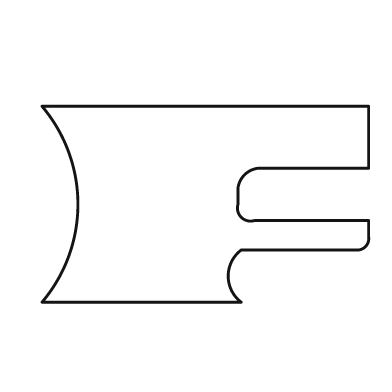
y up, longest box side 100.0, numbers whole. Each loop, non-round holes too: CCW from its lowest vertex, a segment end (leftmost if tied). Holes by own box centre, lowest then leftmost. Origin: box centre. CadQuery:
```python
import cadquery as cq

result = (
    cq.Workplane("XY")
    .moveTo(-50.0, -30.0)
    .lineTo(11.0, -30.0)
    .threePointArc((7.0, -22.0), (11.0, -14.0))
    .lineTo(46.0, -14.0)
    .threePointArc((49.0, -13.0), (50.0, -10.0))
    .lineTo(50.0, -5.0)
    .lineTo(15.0, -5.0)
    .threePointArc((11.0, -4.0), (10.0, 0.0))
    .lineTo(10.0, 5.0)
    .threePointArc((12.0, 9.0), (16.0, 11.0))
    .lineTo(50.0, 11.0)
    .lineTo(50.0, 30.0)
    .lineTo(-50.0, 30.0)
    .threePointArc((-39.0, 0.0), (-50.0, -30.0))
    .close()
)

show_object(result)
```